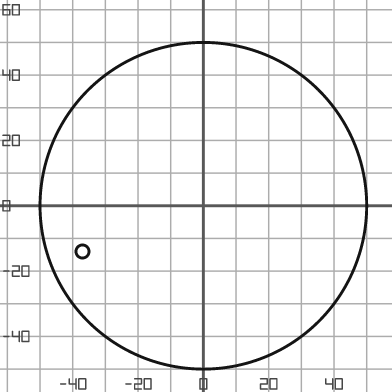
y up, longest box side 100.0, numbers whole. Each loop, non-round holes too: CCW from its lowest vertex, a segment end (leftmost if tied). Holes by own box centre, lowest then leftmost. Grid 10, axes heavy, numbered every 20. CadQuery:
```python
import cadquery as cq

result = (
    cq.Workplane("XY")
    .moveTo(0.0, 0.0)
    .circle(50.0)
    .moveTo(-37.0, -14.0)
    .circle(2.0)
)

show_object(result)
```